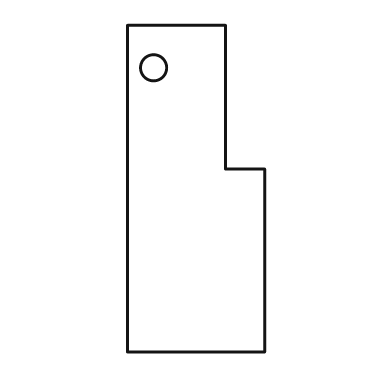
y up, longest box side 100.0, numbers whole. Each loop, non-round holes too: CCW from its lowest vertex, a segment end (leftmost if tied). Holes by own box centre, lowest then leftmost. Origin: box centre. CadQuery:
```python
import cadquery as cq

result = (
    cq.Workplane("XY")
    .moveTo(-21.0, -50.0)
    .lineTo(21.0, -50.0)
    .lineTo(21.0, 6.0)
    .lineTo(9.0, 6.0)
    .lineTo(9.0, 50.0)
    .lineTo(-21.0, 50.0)
    .close()
    .moveTo(-13.0, 37.0)
    .circle(4.0)
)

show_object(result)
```